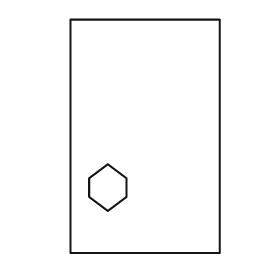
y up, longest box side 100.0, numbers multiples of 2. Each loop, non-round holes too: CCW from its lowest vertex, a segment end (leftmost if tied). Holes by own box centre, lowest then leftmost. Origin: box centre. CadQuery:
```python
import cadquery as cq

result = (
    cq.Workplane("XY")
    .moveTo(-32.0, -50.0)
    .lineTo(32.0, -50.0)
    .lineTo(32.0, 50.0)
    .lineTo(-32.0, 50.0)
    .close()
    .moveTo(-16.0, -32.0)
    .lineTo(-8.0, -26.0)
    .lineTo(-8.0, -18.0)
    .lineTo(-16.0, -12.0)
    .lineTo(-24.0, -18.0)
    .lineTo(-24.0, -26.0)
    .close()
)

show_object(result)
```